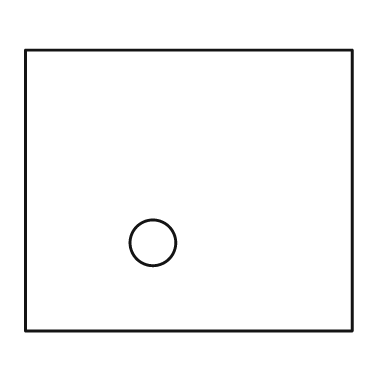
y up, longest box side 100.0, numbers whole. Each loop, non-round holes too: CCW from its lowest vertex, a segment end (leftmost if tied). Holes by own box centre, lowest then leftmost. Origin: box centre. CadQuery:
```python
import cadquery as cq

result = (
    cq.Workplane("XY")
    .moveTo(-50.0, -43.0)
    .lineTo(50.0, -43.0)
    .lineTo(50.0, 43.0)
    .lineTo(-50.0, 43.0)
    .close()
    .moveTo(-11.0, -16.0)
    .circle(7.0)
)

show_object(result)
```